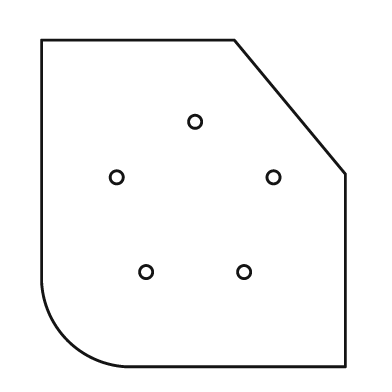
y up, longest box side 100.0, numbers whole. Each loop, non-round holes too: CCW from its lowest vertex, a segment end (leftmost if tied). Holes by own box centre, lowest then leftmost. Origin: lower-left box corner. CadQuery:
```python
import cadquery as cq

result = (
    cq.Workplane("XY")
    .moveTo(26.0, 0.0)
    .lineTo(93.0, 0.0)
    .lineTo(93.0, 59.0)
    .lineTo(59.0, 100.0)
    .lineTo(0.0, 100.0)
    .lineTo(0.0, 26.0)
    .threePointArc((8.0, 8.0), (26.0, 0.0))
    .close()
    .moveTo(32.0, 29.0)
    .circle(2.0)
    .moveTo(62.0, 29.0)
    .circle(2.0)
    .moveTo(23.0, 58.0)
    .circle(2.0)
    .moveTo(71.0, 58.0)
    .circle(2.0)
    .moveTo(47.0, 75.0)
    .circle(2.0)
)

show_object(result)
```